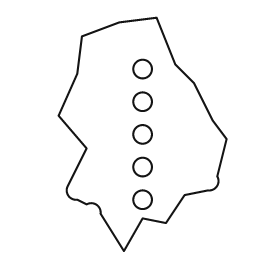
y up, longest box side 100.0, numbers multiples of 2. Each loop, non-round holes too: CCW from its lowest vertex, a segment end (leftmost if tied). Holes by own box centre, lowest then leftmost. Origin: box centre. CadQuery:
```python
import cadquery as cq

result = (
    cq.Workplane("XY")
    .moveTo(-8.0, -50.0)
    .lineTo(0.0, -36.0)
    .lineTo(10.0, -38.0)
    .lineTo(18.0, -26.0)
    .lineTo(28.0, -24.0)
    .threePointArc((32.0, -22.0), (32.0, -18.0))
    .lineTo(36.0, -2.0)
    .lineTo(30.0, 6.0)
    .lineTo(22.0, 22.0)
    .lineTo(14.0, 30.0)
    .lineTo(6.0, 50.0)
    .lineTo(-10.0, 48.0)
    .lineTo(-26.0, 42.0)
    .lineTo(-28.0, 26.0)
    .lineTo(-36.0, 8.0)
    .lineTo(-24.0, -6.0)
    .lineTo(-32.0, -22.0)
    .threePointArc((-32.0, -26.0), (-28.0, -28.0))
    .lineTo(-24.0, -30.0)
    .threePointArc((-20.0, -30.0), (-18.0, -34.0))
    .close()
    .moveTo(0.0, -28.0)
    .circle(4.0)
    .moveTo(0.0, -14.0)
    .circle(4.0)
    .moveTo(0.0, 0.0)
    .circle(4.0)
    .moveTo(0.0, 14.0)
    .circle(4.0)
    .moveTo(0.0, 28.0)
    .circle(4.0)
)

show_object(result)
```